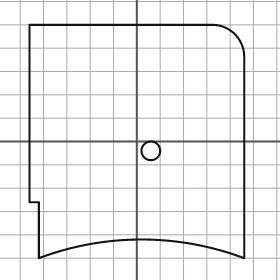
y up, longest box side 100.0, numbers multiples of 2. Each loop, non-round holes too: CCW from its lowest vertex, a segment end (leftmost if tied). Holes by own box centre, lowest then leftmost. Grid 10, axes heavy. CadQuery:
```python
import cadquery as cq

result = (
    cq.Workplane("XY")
    .moveTo(-42.0, -50.0)
    .threePointArc((2.0, -42.0), (46.0, -50.0))
    .lineTo(46.0, 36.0)
    .threePointArc((42.0, 46.0), (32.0, 50.0))
    .lineTo(-46.0, 50.0)
    .lineTo(-46.0, -26.0)
    .lineTo(-42.0, -26.0)
    .close()
    .moveTo(6.0, -4.0)
    .circle(4.0)
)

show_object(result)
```